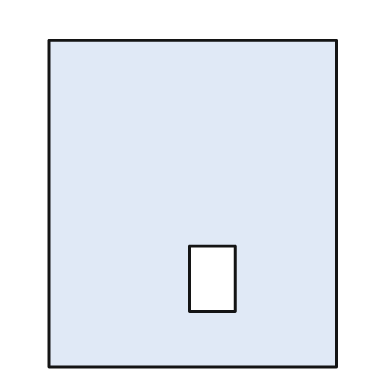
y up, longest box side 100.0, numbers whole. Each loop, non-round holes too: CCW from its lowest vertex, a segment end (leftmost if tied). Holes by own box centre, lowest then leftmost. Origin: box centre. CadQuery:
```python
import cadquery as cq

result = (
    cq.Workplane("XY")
    .moveTo(-44.0, -50.0)
    .lineTo(44.0, -50.0)
    .lineTo(44.0, 50.0)
    .lineTo(-44.0, 50.0)
    .close()
    .moveTo(-1.0, -33.0)
    .lineTo(13.0, -33.0)
    .lineTo(13.0, -13.0)
    .lineTo(-1.0, -13.0)
    .close()
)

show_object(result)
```